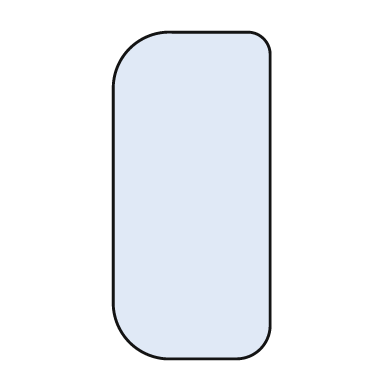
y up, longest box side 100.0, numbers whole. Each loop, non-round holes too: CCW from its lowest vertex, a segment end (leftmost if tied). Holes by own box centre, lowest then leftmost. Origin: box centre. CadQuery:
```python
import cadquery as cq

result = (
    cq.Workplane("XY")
    .moveTo(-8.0, -50.0)
    .lineTo(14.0, -50.0)
    .threePointArc((21.0, -47.0), (24.0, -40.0))
    .lineTo(24.0, 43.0)
    .threePointArc((22.0, 48.0), (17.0, 50.0))
    .lineTo(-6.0, 50.0)
    .threePointArc((-19.0, 45.0), (-24.0, 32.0))
    .lineTo(-24.0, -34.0)
    .threePointArc((-19.0, -45.0), (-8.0, -50.0))
    .close()
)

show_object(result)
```